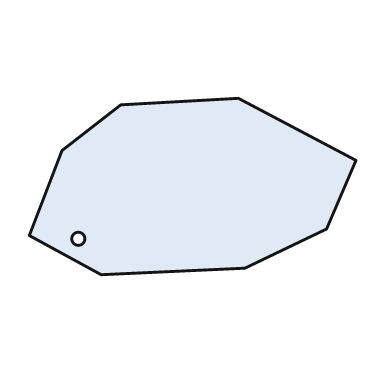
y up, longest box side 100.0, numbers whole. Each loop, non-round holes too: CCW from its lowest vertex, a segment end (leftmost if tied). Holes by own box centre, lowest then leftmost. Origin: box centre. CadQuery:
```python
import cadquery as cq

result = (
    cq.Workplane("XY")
    .moveTo(-28.0, -27.0)
    .lineTo(16.0, -25.0)
    .lineTo(41.0, -13.0)
    .lineTo(50.0, 8.0)
    .lineTo(14.0, 27.0)
    .lineTo(-22.0, 25.0)
    .lineTo(-40.0, 11.0)
    .lineTo(-50.0, -15.0)
    .close()
    .moveTo(-35.0, -16.0)
    .circle(2.0)
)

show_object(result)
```